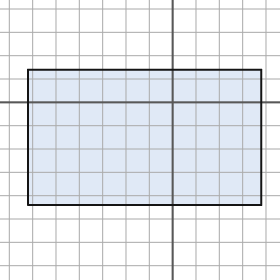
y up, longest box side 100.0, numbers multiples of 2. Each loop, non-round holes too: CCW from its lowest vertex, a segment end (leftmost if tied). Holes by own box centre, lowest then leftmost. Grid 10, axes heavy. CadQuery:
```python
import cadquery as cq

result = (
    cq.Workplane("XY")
    .moveTo(-62.0, -44.0)
    .lineTo(38.0, -44.0)
    .lineTo(38.0, 14.0)
    .lineTo(-62.0, 14.0)
    .close()
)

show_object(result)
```